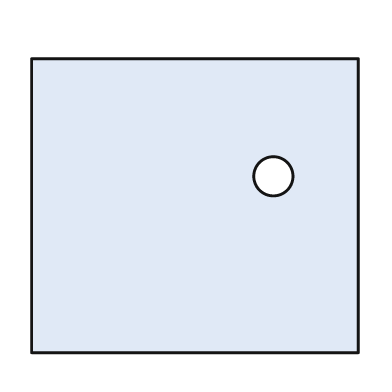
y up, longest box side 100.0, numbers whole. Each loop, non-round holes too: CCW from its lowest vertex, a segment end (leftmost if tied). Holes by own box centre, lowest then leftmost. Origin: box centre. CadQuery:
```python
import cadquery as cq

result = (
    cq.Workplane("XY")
    .moveTo(-50.0, -45.0)
    .lineTo(50.0, -45.0)
    .lineTo(50.0, 45.0)
    .lineTo(-50.0, 45.0)
    .close()
    .moveTo(24.0, 9.0)
    .circle(6.0)
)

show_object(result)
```